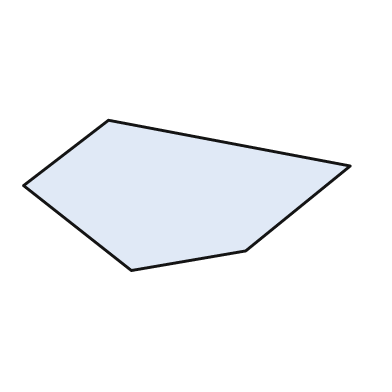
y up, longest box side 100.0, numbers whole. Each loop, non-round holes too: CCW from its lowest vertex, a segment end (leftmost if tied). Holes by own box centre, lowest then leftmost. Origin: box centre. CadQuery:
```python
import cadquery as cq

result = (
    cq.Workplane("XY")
    .moveTo(-17.0, -23.0)
    .lineTo(18.0, -17.0)
    .lineTo(50.0, 9.0)
    .lineTo(-24.0, 23.0)
    .lineTo(-50.0, 3.0)
    .close()
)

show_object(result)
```